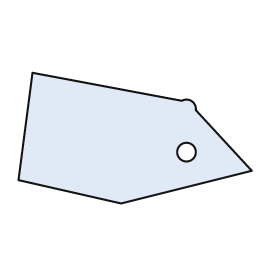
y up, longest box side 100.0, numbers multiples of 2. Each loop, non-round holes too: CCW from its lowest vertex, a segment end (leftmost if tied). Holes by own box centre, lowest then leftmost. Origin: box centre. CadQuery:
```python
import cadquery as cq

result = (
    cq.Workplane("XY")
    .moveTo(-6.0, -28.0)
    .lineTo(50.0, -14.0)
    .lineTo(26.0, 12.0)
    .threePointArc((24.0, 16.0), (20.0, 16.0))
    .lineTo(-44.0, 28.0)
    .lineTo(-50.0, -18.0)
    .close()
    .moveTo(22.0, -6.0)
    .circle(4.0)
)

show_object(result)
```